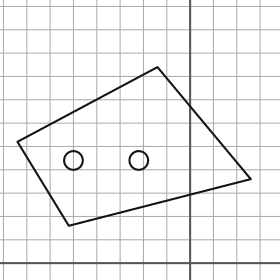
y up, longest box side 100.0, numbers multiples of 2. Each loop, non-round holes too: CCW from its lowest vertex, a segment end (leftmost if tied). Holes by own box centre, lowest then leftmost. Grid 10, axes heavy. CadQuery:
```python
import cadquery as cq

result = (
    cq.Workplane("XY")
    .moveTo(-52.0, 16.0)
    .lineTo(26.0, 36.0)
    .lineTo(-14.0, 84.0)
    .lineTo(-74.0, 52.0)
    .close()
    .moveTo(-50.0, 44.0)
    .circle(4.0)
    .moveTo(-22.0, 44.0)
    .circle(4.0)
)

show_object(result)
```